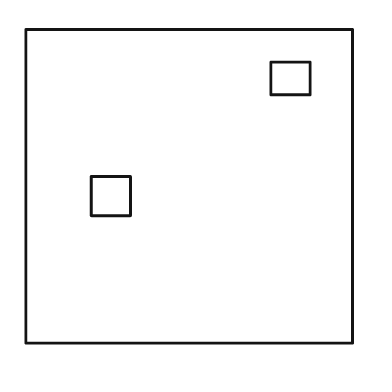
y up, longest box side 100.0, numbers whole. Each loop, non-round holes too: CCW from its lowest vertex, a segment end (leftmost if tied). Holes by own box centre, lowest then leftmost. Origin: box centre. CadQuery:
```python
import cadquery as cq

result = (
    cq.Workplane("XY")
    .moveTo(-50.0, -48.0)
    .lineTo(50.0, -48.0)
    .lineTo(50.0, 48.0)
    .lineTo(-50.0, 48.0)
    .close()
    .moveTo(-30.0, -9.0)
    .lineTo(-18.0, -9.0)
    .lineTo(-18.0, 3.0)
    .lineTo(-30.0, 3.0)
    .close()
    .moveTo(25.0, 28.0)
    .lineTo(37.0, 28.0)
    .lineTo(37.0, 38.0)
    .lineTo(25.0, 38.0)
    .close()
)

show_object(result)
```